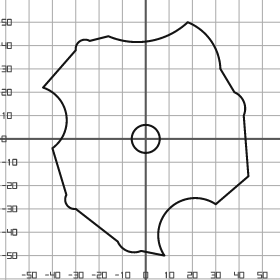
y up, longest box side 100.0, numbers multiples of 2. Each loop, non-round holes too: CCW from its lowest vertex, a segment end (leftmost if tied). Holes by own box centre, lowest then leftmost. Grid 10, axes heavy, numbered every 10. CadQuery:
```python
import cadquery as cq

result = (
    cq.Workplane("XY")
    .moveTo(8.0, -50.0)
    .threePointArc((10.0, -30.0), (30.0, -28.0))
    .lineTo(44.0, -16.0)
    .lineTo(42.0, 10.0)
    .threePointArc((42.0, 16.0), (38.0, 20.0))
    .lineTo(32.0, 30.0)
    .threePointArc((28.0, 42.0), (18.0, 50.0))
    .threePointArc((2.0, 42.0), (-16.0, 44.0))
    .lineTo(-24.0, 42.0)
    .threePointArc((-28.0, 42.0), (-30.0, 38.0))
    .lineTo(-44.0, 22.0)
    .threePointArc((-34.0, 10.0), (-40.0, -4.0))
    .lineTo(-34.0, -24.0)
    .threePointArc((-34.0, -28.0), (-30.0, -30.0))
    .lineTo(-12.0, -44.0)
    .threePointArc((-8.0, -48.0), (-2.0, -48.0))
    .close()
    .moveTo(0.0, 0.0)
    .circle(6.0)
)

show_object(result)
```